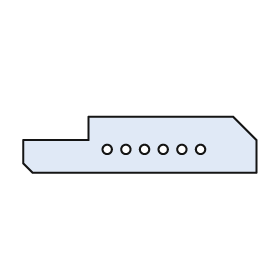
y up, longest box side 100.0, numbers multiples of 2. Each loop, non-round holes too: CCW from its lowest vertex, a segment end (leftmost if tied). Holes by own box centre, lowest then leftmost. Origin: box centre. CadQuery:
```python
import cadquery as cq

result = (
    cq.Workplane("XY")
    .moveTo(-46.0, -12.0)
    .lineTo(50.0, -12.0)
    .lineTo(50.0, 2.0)
    .lineTo(40.0, 12.0)
    .lineTo(-22.0, 12.0)
    .lineTo(-22.0, 2.0)
    .lineTo(-50.0, 2.0)
    .lineTo(-50.0, -8.0)
    .close()
    .moveTo(-14.0, -2.0)
    .circle(2.0)
    .moveTo(-6.0, -2.0)
    .circle(2.0)
    .moveTo(2.0, -2.0)
    .circle(2.0)
    .moveTo(10.0, -2.0)
    .circle(2.0)
    .moveTo(18.0, -2.0)
    .circle(2.0)
    .moveTo(26.0, -2.0)
    .circle(2.0)
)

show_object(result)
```